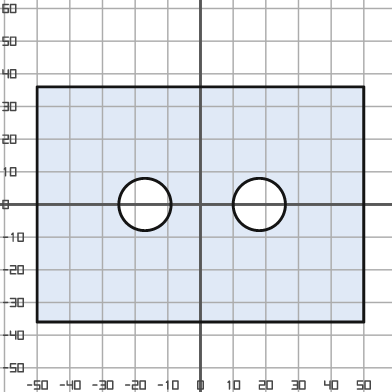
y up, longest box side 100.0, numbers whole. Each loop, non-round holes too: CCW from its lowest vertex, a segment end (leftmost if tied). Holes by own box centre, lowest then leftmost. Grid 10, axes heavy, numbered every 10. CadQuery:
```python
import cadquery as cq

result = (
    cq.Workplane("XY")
    .moveTo(-50.0, -36.0)
    .lineTo(50.0, -36.0)
    .lineTo(50.0, 36.0)
    .lineTo(-50.0, 36.0)
    .close()
    .moveTo(-17.0, 0.0)
    .circle(8.0)
    .moveTo(18.0, 0.0)
    .circle(8.0)
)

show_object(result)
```